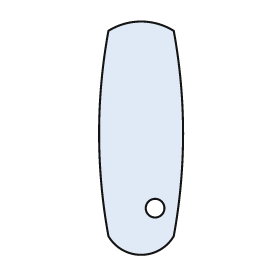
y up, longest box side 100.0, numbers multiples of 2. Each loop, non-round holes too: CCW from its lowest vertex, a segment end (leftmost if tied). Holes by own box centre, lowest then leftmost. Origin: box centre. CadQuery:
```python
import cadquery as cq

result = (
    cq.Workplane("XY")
    .moveTo(-14.0, -42.0)
    .threePointArc((0.0, -50.0), (14.0, -42.0))
    .threePointArc((18.0, 2.0), (14.0, 46.0))
    .threePointArc((0.0, 50.0), (-14.0, 46.0))
    .threePointArc((-18.0, 2.0), (-14.0, -42.0))
    .close()
    .moveTo(6.0, -30.0)
    .circle(4.0)
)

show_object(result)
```